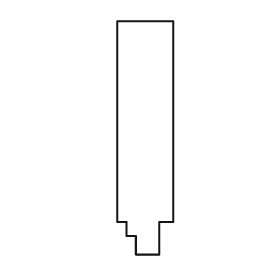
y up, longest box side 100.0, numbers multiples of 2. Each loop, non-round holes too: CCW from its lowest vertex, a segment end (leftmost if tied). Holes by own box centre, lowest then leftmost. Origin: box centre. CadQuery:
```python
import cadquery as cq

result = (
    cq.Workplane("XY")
    .moveTo(-4.0, -50.0)
    .lineTo(6.0, -50.0)
    .lineTo(6.0, -36.0)
    .lineTo(12.0, -36.0)
    .lineTo(12.0, 50.0)
    .lineTo(-12.0, 50.0)
    .lineTo(-12.0, -36.0)
    .lineTo(-8.0, -36.0)
    .lineTo(-8.0, -42.0)
    .lineTo(-4.0, -42.0)
    .close()
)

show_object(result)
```